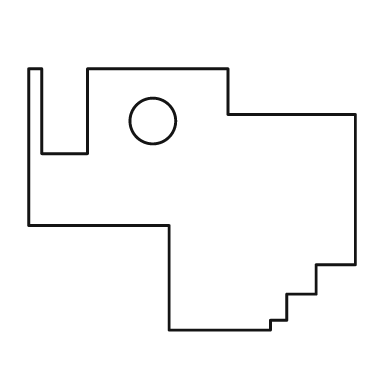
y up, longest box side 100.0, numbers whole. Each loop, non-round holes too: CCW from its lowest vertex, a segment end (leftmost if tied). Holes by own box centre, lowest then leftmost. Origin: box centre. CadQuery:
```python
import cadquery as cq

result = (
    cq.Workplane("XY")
    .moveTo(-7.0, -40.0)
    .lineTo(24.0, -40.0)
    .lineTo(24.0, -37.0)
    .lineTo(29.0, -37.0)
    .lineTo(29.0, -29.0)
    .lineTo(38.0, -29.0)
    .lineTo(38.0, -20.0)
    .lineTo(50.0, -20.0)
    .lineTo(50.0, 26.0)
    .lineTo(11.0, 26.0)
    .lineTo(11.0, 40.0)
    .lineTo(-32.0, 40.0)
    .lineTo(-32.0, 14.0)
    .lineTo(-46.0, 14.0)
    .lineTo(-46.0, 40.0)
    .lineTo(-50.0, 40.0)
    .lineTo(-50.0, -8.0)
    .lineTo(-7.0, -8.0)
    .close()
    .moveTo(-12.0, 24.0)
    .circle(7.0)
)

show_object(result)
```